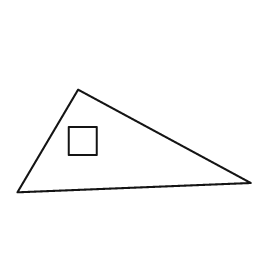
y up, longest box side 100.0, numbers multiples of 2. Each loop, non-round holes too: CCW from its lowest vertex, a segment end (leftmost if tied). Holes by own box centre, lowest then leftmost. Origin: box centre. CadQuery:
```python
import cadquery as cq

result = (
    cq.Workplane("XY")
    .moveTo(-50.0, -22.0)
    .lineTo(50.0, -18.0)
    .lineTo(-24.0, 22.0)
    .close()
    .moveTo(-28.0, -6.0)
    .lineTo(-16.0, -6.0)
    .lineTo(-16.0, 6.0)
    .lineTo(-28.0, 6.0)
    .close()
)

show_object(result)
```